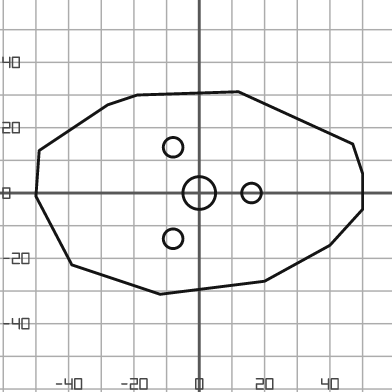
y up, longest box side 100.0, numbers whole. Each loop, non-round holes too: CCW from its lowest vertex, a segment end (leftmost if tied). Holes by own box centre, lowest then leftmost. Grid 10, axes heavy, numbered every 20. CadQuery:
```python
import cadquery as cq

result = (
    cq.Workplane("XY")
    .moveTo(-12.0, -31.0)
    .lineTo(20.0, -27.0)
    .lineTo(40.0, -16.0)
    .lineTo(50.0, -5.0)
    .lineTo(50.0, 6.0)
    .lineTo(47.0, 15.0)
    .lineTo(12.0, 31.0)
    .lineTo(-19.0, 30.0)
    .lineTo(-28.0, 27.0)
    .lineTo(-49.0, 13.0)
    .lineTo(-50.0, -1.0)
    .lineTo(-39.0, -22.0)
    .close()
    .moveTo(-8.0, -14.0)
    .circle(3.0)
    .moveTo(0.0, 0.0)
    .circle(5.0)
    .moveTo(16.0, 0.0)
    .circle(3.0)
    .moveTo(-8.0, 14.0)
    .circle(3.0)
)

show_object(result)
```